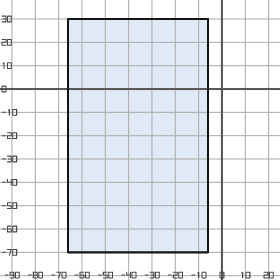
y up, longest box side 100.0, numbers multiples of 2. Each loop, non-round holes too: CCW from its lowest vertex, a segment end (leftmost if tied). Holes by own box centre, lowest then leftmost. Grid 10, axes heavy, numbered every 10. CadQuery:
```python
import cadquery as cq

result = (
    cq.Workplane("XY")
    .moveTo(-66.0, -70.0)
    .lineTo(-6.0, -70.0)
    .lineTo(-6.0, 30.0)
    .lineTo(-66.0, 30.0)
    .close()
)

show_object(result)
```